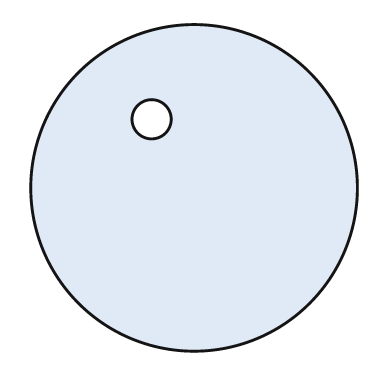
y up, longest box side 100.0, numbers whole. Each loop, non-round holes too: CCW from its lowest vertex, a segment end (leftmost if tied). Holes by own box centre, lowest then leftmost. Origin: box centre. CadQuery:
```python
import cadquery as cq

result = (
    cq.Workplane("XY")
    .moveTo(0.0, 0.0)
    .circle(50.0)
    .moveTo(-13.0, 21.0)
    .circle(6.0)
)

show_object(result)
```